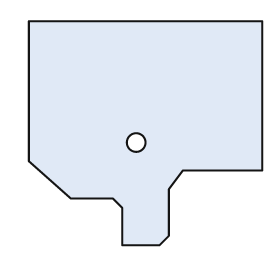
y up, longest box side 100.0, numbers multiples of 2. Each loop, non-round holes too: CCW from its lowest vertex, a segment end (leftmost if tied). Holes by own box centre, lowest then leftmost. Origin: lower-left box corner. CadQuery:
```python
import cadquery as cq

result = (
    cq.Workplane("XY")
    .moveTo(40.0, 0.0)
    .lineTo(56.0, 0.0)
    .lineTo(60.0, 4.0)
    .lineTo(60.0, 24.0)
    .lineTo(66.0, 32.0)
    .lineTo(100.0, 32.0)
    .lineTo(100.0, 96.0)
    .lineTo(0.0, 96.0)
    .lineTo(0.0, 36.0)
    .lineTo(18.0, 20.0)
    .lineTo(36.0, 20.0)
    .lineTo(40.0, 16.0)
    .close()
    .moveTo(46.0, 44.0)
    .circle(4.0)
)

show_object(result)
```